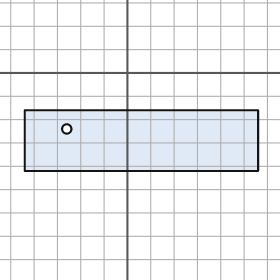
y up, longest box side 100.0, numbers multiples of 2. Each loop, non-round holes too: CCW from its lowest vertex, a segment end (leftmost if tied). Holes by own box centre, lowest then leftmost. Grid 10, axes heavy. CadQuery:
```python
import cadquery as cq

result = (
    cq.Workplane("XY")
    .moveTo(-44.0, -42.0)
    .lineTo(56.0, -42.0)
    .lineTo(56.0, -16.0)
    .lineTo(-44.0, -16.0)
    .close()
    .moveTo(-26.0, -24.0)
    .circle(2.0)
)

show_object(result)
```